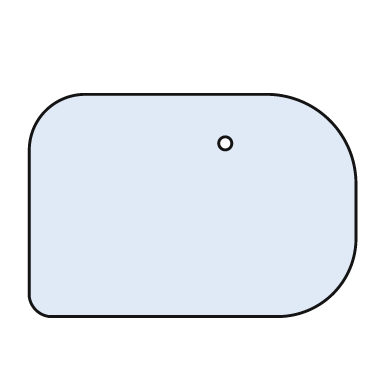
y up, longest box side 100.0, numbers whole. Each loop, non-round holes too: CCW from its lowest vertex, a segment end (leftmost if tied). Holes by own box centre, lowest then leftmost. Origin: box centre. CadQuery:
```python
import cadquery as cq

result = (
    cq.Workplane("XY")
    .moveTo(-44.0, -34.0)
    .lineTo(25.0, -34.0)
    .threePointArc((43.0, -27.0), (50.0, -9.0))
    .lineTo(50.0, 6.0)
    .threePointArc((42.0, 26.0), (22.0, 34.0))
    .lineTo(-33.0, 34.0)
    .threePointArc((-45.0, 29.0), (-50.0, 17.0))
    .lineTo(-50.0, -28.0)
    .threePointArc((-48.0, -32.0), (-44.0, -34.0))
    .close()
    .moveTo(10.0, 19.0)
    .circle(2.0)
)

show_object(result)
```